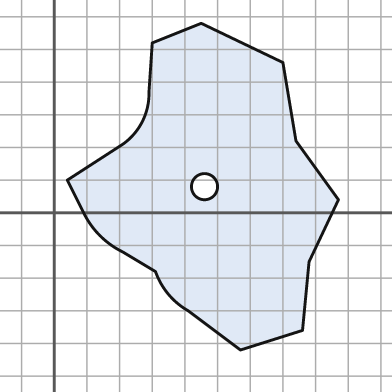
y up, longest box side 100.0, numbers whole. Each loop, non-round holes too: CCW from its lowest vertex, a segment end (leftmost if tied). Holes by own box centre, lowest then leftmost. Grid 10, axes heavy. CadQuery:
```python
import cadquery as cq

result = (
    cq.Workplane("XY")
    .moveTo(57.0, -42.0)
    .lineTo(76.0, -36.0)
    .lineTo(78.0, -15.0)
    .lineTo(87.0, 4.0)
    .lineTo(74.0, 22.0)
    .lineTo(70.0, 46.0)
    .lineTo(45.0, 58.0)
    .lineTo(30.0, 52.0)
    .lineTo(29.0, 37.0)
    .threePointArc((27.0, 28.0), (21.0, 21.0))
    .lineTo(4.0, 10.0)
    .lineTo(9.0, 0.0)
    .threePointArc((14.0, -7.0), (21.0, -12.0))
    .lineTo(31.0, -18.0)
    .threePointArc((35.0, -25.0), (41.0, -30.0))
    .close()
    .moveTo(46.0, 8.0)
    .circle(4.0)
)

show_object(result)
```